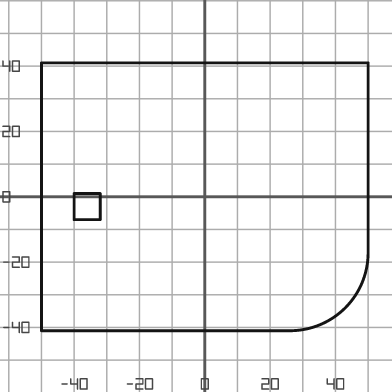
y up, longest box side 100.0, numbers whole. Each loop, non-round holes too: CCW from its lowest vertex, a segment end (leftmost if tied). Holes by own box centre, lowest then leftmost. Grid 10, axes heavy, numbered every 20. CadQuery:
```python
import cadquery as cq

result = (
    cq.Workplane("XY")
    .moveTo(-50.0, -41.0)
    .lineTo(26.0, -41.0)
    .threePointArc((43.0, -34.0), (50.0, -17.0))
    .lineTo(50.0, 41.0)
    .lineTo(-50.0, 41.0)
    .close()
    .moveTo(-40.0, -7.0)
    .lineTo(-32.0, -7.0)
    .lineTo(-32.0, 1.0)
    .lineTo(-40.0, 1.0)
    .close()
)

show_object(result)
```